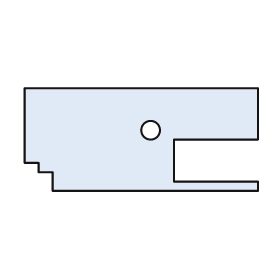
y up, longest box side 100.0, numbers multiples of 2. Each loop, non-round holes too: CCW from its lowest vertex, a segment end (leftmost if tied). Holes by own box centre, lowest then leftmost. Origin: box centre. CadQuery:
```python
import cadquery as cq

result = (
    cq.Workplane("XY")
    .moveTo(-38.0, -22.0)
    .lineTo(50.0, -22.0)
    .lineTo(50.0, -18.0)
    .lineTo(14.0, -18.0)
    .lineTo(14.0, 0.0)
    .lineTo(50.0, 0.0)
    .lineTo(50.0, 22.0)
    .lineTo(-50.0, 22.0)
    .lineTo(-50.0, -10.0)
    .lineTo(-44.0, -10.0)
    .lineTo(-44.0, -14.0)
    .lineTo(-38.0, -14.0)
    .close()
    .moveTo(4.0, 4.0)
    .circle(4.0)
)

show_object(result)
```